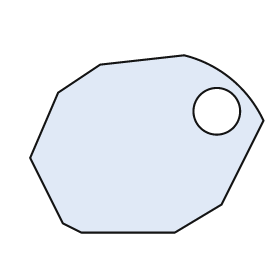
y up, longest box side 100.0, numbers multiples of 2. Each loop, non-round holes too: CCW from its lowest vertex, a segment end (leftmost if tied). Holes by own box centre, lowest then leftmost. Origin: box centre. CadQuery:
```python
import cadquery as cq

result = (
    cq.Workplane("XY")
    .moveTo(-28.0, -38.0)
    .lineTo(12.0, -38.0)
    .lineTo(32.0, -26.0)
    .lineTo(50.0, 10.0)
    .threePointArc((36.0, 28.0), (16.0, 38.0))
    .lineTo(-20.0, 34.0)
    .lineTo(-38.0, 22.0)
    .lineTo(-50.0, -6.0)
    .lineTo(-36.0, -34.0)
    .close()
    .moveTo(30.0, 14.0)
    .circle(10.0)
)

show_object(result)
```